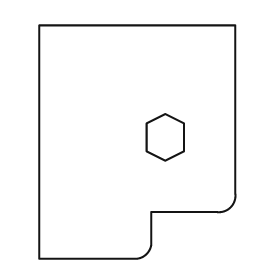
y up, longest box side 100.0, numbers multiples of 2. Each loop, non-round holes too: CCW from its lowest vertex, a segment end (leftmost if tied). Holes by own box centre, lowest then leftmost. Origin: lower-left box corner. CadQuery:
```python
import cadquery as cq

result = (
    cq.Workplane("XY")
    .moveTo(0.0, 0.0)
    .lineTo(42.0, 0.0)
    .threePointArc((46.0, 2.0), (48.0, 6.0))
    .lineTo(48.0, 20.0)
    .lineTo(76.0, 20.0)
    .threePointArc((82.0, 22.0), (84.0, 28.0))
    .lineTo(84.0, 100.0)
    .lineTo(0.0, 100.0)
    .close()
    .moveTo(54.0, 42.0)
    .lineTo(62.0, 46.0)
    .lineTo(62.0, 58.0)
    .lineTo(54.0, 62.0)
    .lineTo(46.0, 58.0)
    .lineTo(46.0, 46.0)
    .close()
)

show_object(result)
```